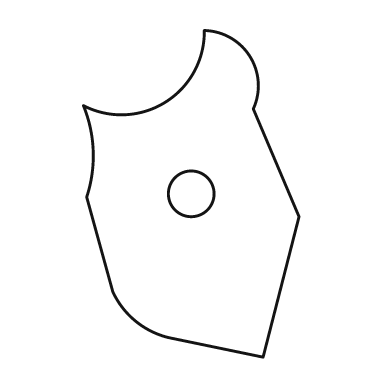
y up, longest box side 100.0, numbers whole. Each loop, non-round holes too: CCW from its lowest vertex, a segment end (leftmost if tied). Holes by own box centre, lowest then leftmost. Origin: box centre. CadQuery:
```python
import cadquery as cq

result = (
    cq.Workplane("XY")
    .moveTo(22.0, -50.0)
    .lineTo(33.0, -7.0)
    .lineTo(19.0, 26.0)
    .threePointArc((18.0, 42.0), (4.0, 50.0))
    .threePointArc((-8.0, 28.0), (-33.0, 27.0))
    .threePointArc((-30.0, 13.0), (-32.0, -1.0))
    .lineTo(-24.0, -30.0)
    .threePointArc((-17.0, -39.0), (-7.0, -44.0))
    .close()
    .moveTo(0.0, 0.0)
    .circle(7.0)
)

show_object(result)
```